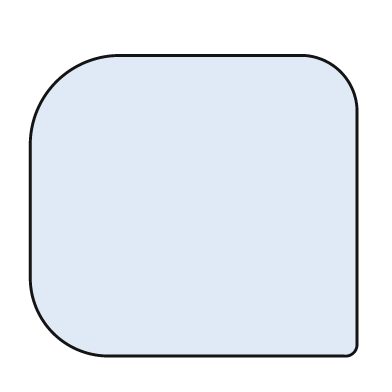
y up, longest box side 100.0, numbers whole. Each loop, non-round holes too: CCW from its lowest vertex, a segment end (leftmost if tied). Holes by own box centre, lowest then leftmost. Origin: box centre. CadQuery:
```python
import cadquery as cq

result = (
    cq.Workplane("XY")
    .moveTo(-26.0, -46.0)
    .lineTo(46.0, -46.0)
    .threePointArc((49.0, -45.0), (50.0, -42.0))
    .lineTo(50.0, 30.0)
    .threePointArc((45.0, 41.0), (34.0, 46.0))
    .lineTo(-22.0, 46.0)
    .threePointArc((-42.0, 38.0), (-50.0, 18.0))
    .lineTo(-50.0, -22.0)
    .threePointArc((-43.0, -39.0), (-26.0, -46.0))
    .close()
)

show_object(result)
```